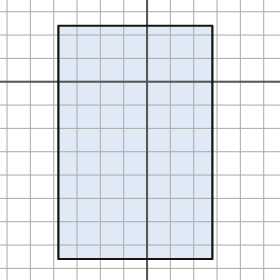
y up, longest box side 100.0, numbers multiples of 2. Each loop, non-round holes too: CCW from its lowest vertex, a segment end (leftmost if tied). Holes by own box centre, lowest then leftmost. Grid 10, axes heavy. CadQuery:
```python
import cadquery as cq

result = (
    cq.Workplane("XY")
    .moveTo(-38.0, -76.0)
    .lineTo(28.0, -76.0)
    .lineTo(28.0, 24.0)
    .lineTo(-38.0, 24.0)
    .close()
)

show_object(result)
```